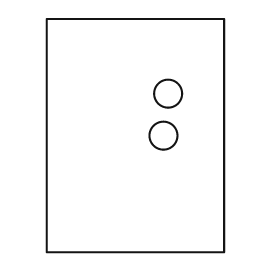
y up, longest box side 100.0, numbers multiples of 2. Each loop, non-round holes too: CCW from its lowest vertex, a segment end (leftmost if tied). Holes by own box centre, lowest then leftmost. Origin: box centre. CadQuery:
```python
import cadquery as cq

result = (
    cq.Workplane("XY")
    .moveTo(-38.0, -50.0)
    .lineTo(38.0, -50.0)
    .lineTo(38.0, 50.0)
    .lineTo(-38.0, 50.0)
    .close()
    .moveTo(12.0, 0.0)
    .circle(6.0)
    .moveTo(14.0, 18.0)
    .circle(6.0)
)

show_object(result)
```